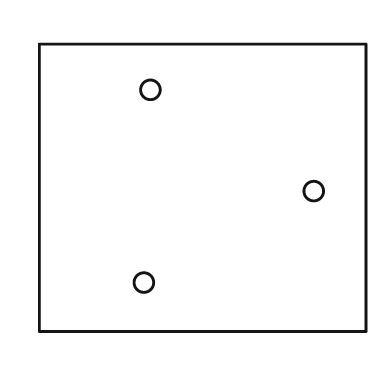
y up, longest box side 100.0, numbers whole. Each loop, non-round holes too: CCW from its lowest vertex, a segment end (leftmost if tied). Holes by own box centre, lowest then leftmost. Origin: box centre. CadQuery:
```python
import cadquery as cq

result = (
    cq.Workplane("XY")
    .moveTo(-50.0, -44.0)
    .lineTo(50.0, -44.0)
    .lineTo(50.0, 44.0)
    .lineTo(-50.0, 44.0)
    .close()
    .moveTo(-18.0, -29.0)
    .circle(3.0)
    .moveTo(34.0, -1.0)
    .circle(3.0)
    .moveTo(-16.0, 30.0)
    .circle(3.0)
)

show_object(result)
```